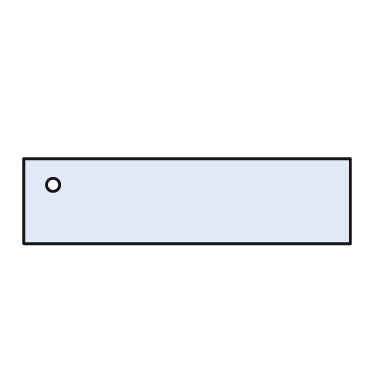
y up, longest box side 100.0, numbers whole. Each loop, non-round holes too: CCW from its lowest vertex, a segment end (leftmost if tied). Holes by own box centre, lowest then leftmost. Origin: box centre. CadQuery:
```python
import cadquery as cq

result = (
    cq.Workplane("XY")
    .moveTo(-50.0, -13.0)
    .lineTo(50.0, -13.0)
    .lineTo(50.0, 13.0)
    .lineTo(-50.0, 13.0)
    .close()
    .moveTo(-41.0, 5.0)
    .circle(2.0)
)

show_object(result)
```